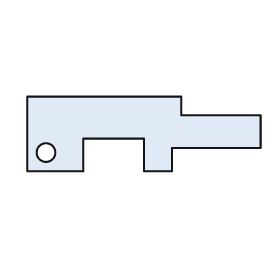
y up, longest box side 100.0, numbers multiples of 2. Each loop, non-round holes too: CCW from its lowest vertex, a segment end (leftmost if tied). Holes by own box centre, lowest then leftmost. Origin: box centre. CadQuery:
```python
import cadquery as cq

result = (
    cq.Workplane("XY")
    .moveTo(-50.0, -16.0)
    .lineTo(-26.0, -16.0)
    .lineTo(-26.0, -2.0)
    .lineTo(0.0, -2.0)
    .lineTo(0.0, -16.0)
    .lineTo(12.0, -16.0)
    .lineTo(12.0, -6.0)
    .lineTo(50.0, -6.0)
    .lineTo(50.0, 8.0)
    .lineTo(16.0, 8.0)
    .lineTo(16.0, 16.0)
    .lineTo(-50.0, 16.0)
    .close()
    .moveTo(-42.0, -8.0)
    .circle(4.0)
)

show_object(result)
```